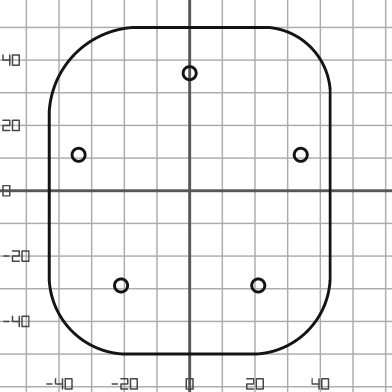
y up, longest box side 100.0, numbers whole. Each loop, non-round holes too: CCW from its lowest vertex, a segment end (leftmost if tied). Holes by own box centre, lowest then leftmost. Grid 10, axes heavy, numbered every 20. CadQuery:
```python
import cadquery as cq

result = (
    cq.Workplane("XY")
    .moveTo(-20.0, -50.0)
    .lineTo(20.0, -50.0)
    .threePointArc((36.0, -43.0), (43.0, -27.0))
    .lineTo(43.0, 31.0)
    .threePointArc((37.0, 44.0), (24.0, 50.0))
    .lineTo(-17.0, 50.0)
    .threePointArc((-35.0, 42.0), (-43.0, 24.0))
    .lineTo(-43.0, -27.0)
    .threePointArc((-36.0, -43.0), (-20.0, -50.0))
    .close()
    .moveTo(-21.0, -29.0)
    .circle(2.0)
    .moveTo(21.0, -29.0)
    .circle(2.0)
    .moveTo(-34.0, 11.0)
    .circle(2.0)
    .moveTo(34.0, 11.0)
    .circle(2.0)
    .moveTo(0.0, 36.0)
    .circle(2.0)
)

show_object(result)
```